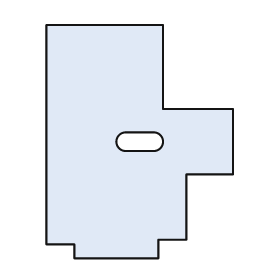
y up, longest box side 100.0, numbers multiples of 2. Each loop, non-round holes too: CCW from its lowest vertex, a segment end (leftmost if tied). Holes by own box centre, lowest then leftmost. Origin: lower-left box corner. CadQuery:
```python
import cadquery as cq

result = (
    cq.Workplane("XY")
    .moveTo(12.0, 0.0)
    .lineTo(48.0, 0.0)
    .lineTo(48.0, 8.0)
    .lineTo(60.0, 8.0)
    .lineTo(60.0, 36.0)
    .lineTo(80.0, 36.0)
    .lineTo(80.0, 64.0)
    .lineTo(50.0, 64.0)
    .lineTo(50.0, 100.0)
    .lineTo(0.0, 100.0)
    .lineTo(0.0, 6.0)
    .lineTo(12.0, 6.0)
    .close()
    .moveTo(34.0, 46.0)
    .lineTo(46.0, 46.0)
    .threePointArc((50.0, 50.0), (46.0, 54.0))
    .lineTo(34.0, 54.0)
    .threePointArc((30.0, 50.0), (34.0, 46.0))
    .close()
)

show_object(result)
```